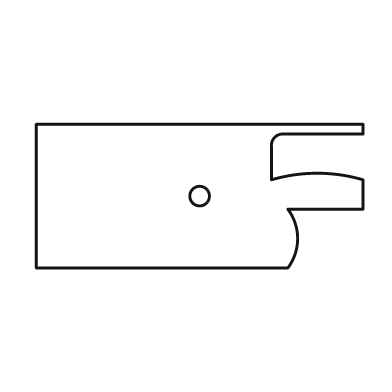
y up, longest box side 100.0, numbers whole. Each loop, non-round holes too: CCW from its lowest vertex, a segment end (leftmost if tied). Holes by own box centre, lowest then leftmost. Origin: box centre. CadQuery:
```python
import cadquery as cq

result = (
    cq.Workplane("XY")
    .moveTo(-50.0, -22.0)
    .lineTo(27.0, -22.0)
    .threePointArc((30.0, -13.0), (27.0, -4.0))
    .lineTo(50.0, -4.0)
    .lineTo(50.0, 5.0)
    .threePointArc((36.0, 7.0), (22.0, 5.0))
    .lineTo(22.0, 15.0)
    .threePointArc((23.0, 18.0), (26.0, 19.0))
    .lineTo(50.0, 19.0)
    .lineTo(50.0, 22.0)
    .lineTo(-50.0, 22.0)
    .close()
    .moveTo(0.0, 0.0)
    .circle(3.0)
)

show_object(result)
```